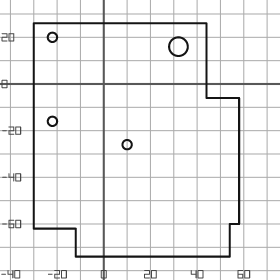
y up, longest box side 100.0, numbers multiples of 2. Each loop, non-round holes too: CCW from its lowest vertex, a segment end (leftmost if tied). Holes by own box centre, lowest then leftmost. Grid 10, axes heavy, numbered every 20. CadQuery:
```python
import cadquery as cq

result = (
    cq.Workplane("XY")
    .moveTo(-12.0, -74.0)
    .lineTo(54.0, -74.0)
    .lineTo(54.0, -60.0)
    .lineTo(58.0, -60.0)
    .lineTo(58.0, -6.0)
    .lineTo(44.0, -6.0)
    .lineTo(44.0, 26.0)
    .lineTo(-30.0, 26.0)
    .lineTo(-30.0, -62.0)
    .lineTo(-12.0, -62.0)
    .close()
    .moveTo(10.0, -26.0)
    .circle(2.0)
    .moveTo(-22.0, -16.0)
    .circle(2.0)
    .moveTo(32.0, 16.0)
    .circle(4.0)
    .moveTo(-22.0, 20.0)
    .circle(2.0)
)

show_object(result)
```